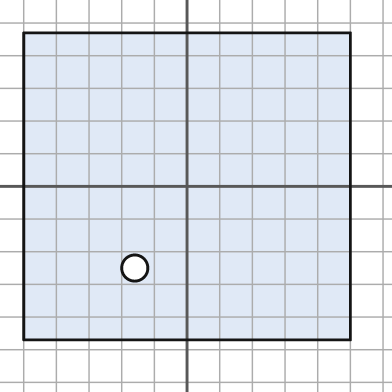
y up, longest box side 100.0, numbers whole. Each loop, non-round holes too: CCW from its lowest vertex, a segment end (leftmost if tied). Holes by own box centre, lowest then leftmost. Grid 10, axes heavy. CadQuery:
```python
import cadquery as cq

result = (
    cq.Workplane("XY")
    .moveTo(-50.0, -47.0)
    .lineTo(50.0, -47.0)
    .lineTo(50.0, 47.0)
    .lineTo(-50.0, 47.0)
    .close()
    .moveTo(-16.0, -25.0)
    .circle(4.0)
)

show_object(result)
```